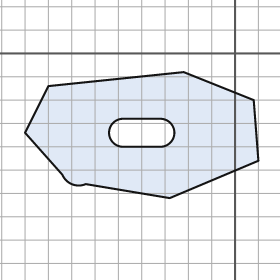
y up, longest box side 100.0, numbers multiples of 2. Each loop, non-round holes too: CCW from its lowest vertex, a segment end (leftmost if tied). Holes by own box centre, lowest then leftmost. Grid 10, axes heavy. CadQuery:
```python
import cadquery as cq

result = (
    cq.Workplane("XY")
    .moveTo(-28.0, -62.0)
    .lineTo(10.0, -46.0)
    .lineTo(8.0, -20.0)
    .lineTo(-22.0, -8.0)
    .lineTo(-80.0, -14.0)
    .lineTo(-90.0, -34.0)
    .lineTo(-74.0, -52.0)
    .threePointArc((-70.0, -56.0), (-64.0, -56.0))
    .close()
    .moveTo(-48.0, -40.0)
    .lineTo(-32.0, -40.0)
    .threePointArc((-26.0, -34.0), (-32.0, -28.0))
    .lineTo(-48.0, -28.0)
    .threePointArc((-54.0, -34.0), (-48.0, -40.0))
    .close()
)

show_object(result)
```